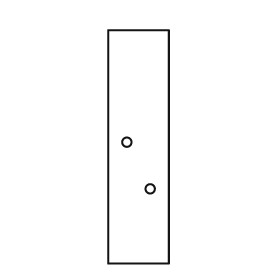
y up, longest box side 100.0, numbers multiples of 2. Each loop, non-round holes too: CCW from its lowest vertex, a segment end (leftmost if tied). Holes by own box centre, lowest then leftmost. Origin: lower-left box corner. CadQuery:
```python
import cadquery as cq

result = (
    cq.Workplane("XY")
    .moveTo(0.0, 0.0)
    .lineTo(26.0, 0.0)
    .lineTo(26.0, 100.0)
    .lineTo(0.0, 100.0)
    .close()
    .moveTo(18.0, 32.0)
    .circle(2.0)
    .moveTo(8.0, 52.0)
    .circle(2.0)
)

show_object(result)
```